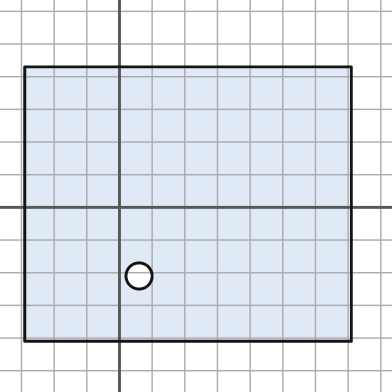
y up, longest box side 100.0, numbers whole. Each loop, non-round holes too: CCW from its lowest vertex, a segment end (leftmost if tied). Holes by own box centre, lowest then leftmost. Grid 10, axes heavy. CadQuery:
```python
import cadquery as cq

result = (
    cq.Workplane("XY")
    .moveTo(-29.0, -41.0)
    .lineTo(71.0, -41.0)
    .lineTo(71.0, 43.0)
    .lineTo(-29.0, 43.0)
    .close()
    .moveTo(6.0, -21.0)
    .circle(4.0)
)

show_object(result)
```